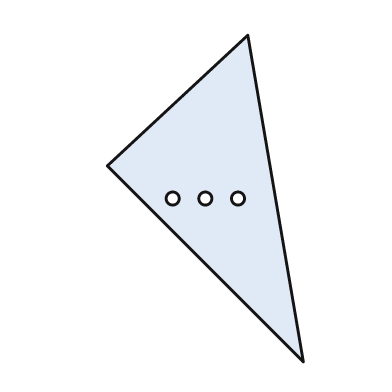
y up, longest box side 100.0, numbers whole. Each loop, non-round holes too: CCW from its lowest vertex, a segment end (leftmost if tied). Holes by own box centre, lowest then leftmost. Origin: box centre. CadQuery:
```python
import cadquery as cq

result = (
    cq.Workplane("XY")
    .moveTo(30.0, -50.0)
    .lineTo(13.0, 50.0)
    .lineTo(-30.0, 10.0)
    .close()
    .moveTo(-10.0, 0.0)
    .circle(2.0)
    .moveTo(0.0, 0.0)
    .circle(2.0)
    .moveTo(10.0, 0.0)
    .circle(2.0)
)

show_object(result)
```